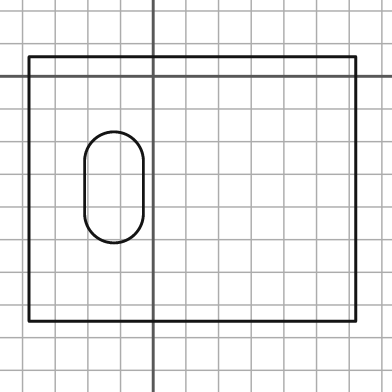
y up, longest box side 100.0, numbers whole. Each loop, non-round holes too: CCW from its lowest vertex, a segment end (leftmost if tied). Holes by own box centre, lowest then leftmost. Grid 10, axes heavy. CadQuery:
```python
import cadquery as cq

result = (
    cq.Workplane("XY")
    .moveTo(-38.0, -75.0)
    .lineTo(62.0, -75.0)
    .lineTo(62.0, 6.0)
    .lineTo(-38.0, 6.0)
    .close()
    .moveTo(-21.0, -42.0)
    .threePointArc((-12.0, -51.0), (-3.0, -42.0))
    .lineTo(-3.0, -26.0)
    .threePointArc((-12.0, -17.0), (-21.0, -26.0))
    .close()
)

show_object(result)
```